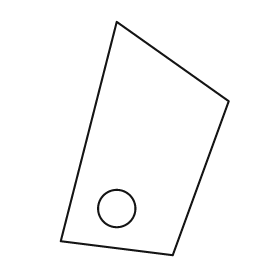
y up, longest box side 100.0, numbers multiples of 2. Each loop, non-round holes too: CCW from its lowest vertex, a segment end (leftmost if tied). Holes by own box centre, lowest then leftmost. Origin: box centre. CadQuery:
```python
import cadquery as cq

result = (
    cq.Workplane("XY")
    .moveTo(12.0, -50.0)
    .lineTo(36.0, 16.0)
    .lineTo(-12.0, 50.0)
    .lineTo(-36.0, -44.0)
    .close()
    .moveTo(-12.0, -30.0)
    .circle(8.0)
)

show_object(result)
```